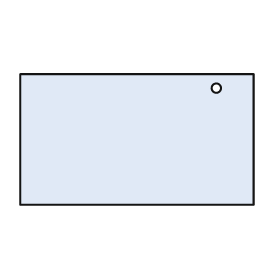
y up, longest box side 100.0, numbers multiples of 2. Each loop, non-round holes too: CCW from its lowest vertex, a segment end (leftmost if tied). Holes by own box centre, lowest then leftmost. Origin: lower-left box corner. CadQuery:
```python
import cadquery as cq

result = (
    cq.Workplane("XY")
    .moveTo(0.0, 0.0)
    .lineTo(100.0, 0.0)
    .lineTo(100.0, 56.0)
    .lineTo(0.0, 56.0)
    .close()
    .moveTo(84.0, 50.0)
    .circle(2.0)
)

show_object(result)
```